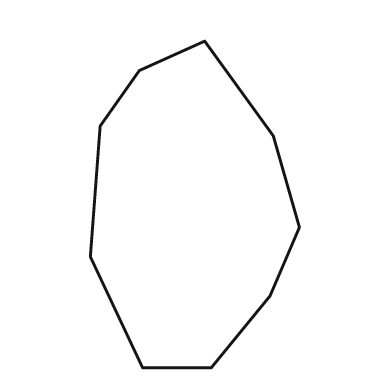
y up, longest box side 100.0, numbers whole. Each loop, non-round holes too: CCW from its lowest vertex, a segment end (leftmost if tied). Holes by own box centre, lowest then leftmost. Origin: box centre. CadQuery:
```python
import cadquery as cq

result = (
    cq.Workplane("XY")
    .moveTo(-16.0, -50.0)
    .lineTo(5.0, -50.0)
    .lineTo(23.0, -28.0)
    .lineTo(32.0, -7.0)
    .lineTo(24.0, 21.0)
    .lineTo(3.0, 50.0)
    .lineTo(-17.0, 41.0)
    .lineTo(-29.0, 24.0)
    .lineTo(-32.0, -16.0)
    .close()
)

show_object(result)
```